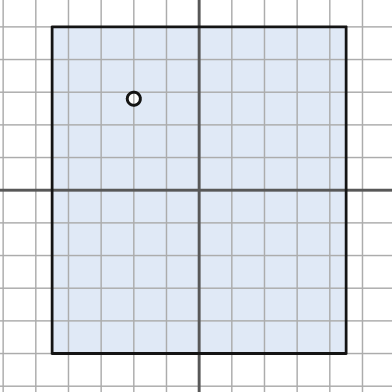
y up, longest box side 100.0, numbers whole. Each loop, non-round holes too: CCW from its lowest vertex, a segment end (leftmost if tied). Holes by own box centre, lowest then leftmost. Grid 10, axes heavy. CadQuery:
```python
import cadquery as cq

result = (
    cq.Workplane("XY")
    .moveTo(-45.0, -50.0)
    .lineTo(45.0, -50.0)
    .lineTo(45.0, 50.0)
    .lineTo(-45.0, 50.0)
    .close()
    .moveTo(-20.0, 28.0)
    .circle(2.0)
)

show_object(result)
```